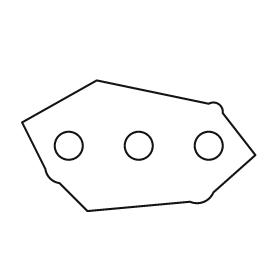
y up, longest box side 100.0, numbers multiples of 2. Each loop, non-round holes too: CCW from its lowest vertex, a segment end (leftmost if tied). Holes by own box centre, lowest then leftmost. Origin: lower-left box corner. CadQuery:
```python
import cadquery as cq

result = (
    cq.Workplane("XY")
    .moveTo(28.0, 0.0)
    .lineTo(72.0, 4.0)
    .threePointArc((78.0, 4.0), (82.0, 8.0))
    .lineTo(100.0, 24.0)
    .lineTo(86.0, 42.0)
    .threePointArc((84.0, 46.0), (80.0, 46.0))
    .lineTo(32.0, 56.0)
    .lineTo(0.0, 38.0)
    .lineTo(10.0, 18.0)
    .threePointArc((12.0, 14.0), (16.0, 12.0))
    .close()
    .moveTo(20.0, 28.0)
    .circle(6.0)
    .moveTo(50.0, 28.0)
    .circle(6.0)
    .moveTo(80.0, 28.0)
    .circle(6.0)
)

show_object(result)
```